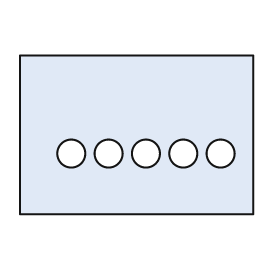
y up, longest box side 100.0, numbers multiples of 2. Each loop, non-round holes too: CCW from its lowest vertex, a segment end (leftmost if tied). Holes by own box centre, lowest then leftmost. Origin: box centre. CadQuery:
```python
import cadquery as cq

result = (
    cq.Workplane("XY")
    .moveTo(-50.0, -34.0)
    .lineTo(50.0, -34.0)
    .lineTo(50.0, 34.0)
    .lineTo(-50.0, 34.0)
    .close()
    .moveTo(-28.0, -8.0)
    .circle(6.0)
    .moveTo(-12.0, -8.0)
    .circle(6.0)
    .moveTo(4.0, -8.0)
    .circle(6.0)
    .moveTo(20.0, -8.0)
    .circle(6.0)
    .moveTo(36.0, -8.0)
    .circle(6.0)
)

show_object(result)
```